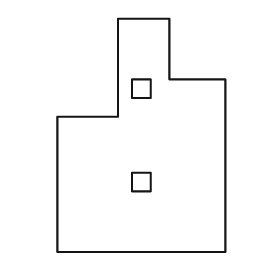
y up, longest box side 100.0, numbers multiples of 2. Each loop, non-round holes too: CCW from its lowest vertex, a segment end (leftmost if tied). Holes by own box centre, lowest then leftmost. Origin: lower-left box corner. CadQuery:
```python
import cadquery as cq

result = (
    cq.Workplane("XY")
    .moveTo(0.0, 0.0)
    .lineTo(72.0, 0.0)
    .lineTo(72.0, 74.0)
    .lineTo(48.0, 74.0)
    .lineTo(48.0, 100.0)
    .lineTo(26.0, 100.0)
    .lineTo(26.0, 58.0)
    .lineTo(0.0, 58.0)
    .close()
    .moveTo(32.0, 26.0)
    .lineTo(40.0, 26.0)
    .lineTo(40.0, 34.0)
    .lineTo(32.0, 34.0)
    .close()
    .moveTo(32.0, 66.0)
    .lineTo(40.0, 66.0)
    .lineTo(40.0, 74.0)
    .lineTo(32.0, 74.0)
    .close()
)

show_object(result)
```